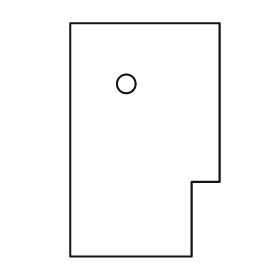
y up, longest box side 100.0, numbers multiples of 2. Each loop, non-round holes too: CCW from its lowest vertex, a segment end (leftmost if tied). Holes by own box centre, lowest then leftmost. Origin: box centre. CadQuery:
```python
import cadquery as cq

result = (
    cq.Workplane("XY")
    .moveTo(-32.0, -50.0)
    .lineTo(20.0, -50.0)
    .lineTo(20.0, -18.0)
    .lineTo(32.0, -18.0)
    .lineTo(32.0, 50.0)
    .lineTo(-32.0, 50.0)
    .close()
    .moveTo(-8.0, 24.0)
    .circle(4.0)
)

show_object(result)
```